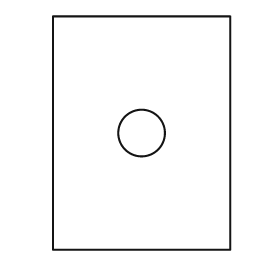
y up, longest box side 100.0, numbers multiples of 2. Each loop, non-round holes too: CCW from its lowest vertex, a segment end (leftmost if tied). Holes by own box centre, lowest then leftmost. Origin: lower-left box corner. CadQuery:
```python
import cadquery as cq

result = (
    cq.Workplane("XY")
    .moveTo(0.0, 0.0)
    .lineTo(76.0, 0.0)
    .lineTo(76.0, 100.0)
    .lineTo(0.0, 100.0)
    .close()
    .moveTo(38.0, 50.0)
    .circle(10.0)
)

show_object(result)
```